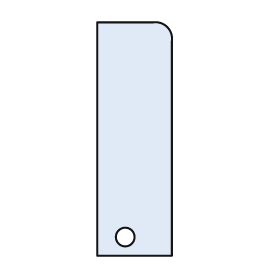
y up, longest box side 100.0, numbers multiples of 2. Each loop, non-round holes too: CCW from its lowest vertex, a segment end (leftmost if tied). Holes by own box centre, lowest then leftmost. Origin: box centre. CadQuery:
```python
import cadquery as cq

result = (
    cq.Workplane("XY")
    .moveTo(-16.0, -50.0)
    .lineTo(16.0, -50.0)
    .lineTo(16.0, 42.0)
    .threePointArc((14.0, 48.0), (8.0, 50.0))
    .lineTo(-16.0, 50.0)
    .close()
    .moveTo(-4.0, -42.0)
    .circle(4.0)
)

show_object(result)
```